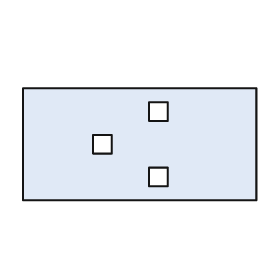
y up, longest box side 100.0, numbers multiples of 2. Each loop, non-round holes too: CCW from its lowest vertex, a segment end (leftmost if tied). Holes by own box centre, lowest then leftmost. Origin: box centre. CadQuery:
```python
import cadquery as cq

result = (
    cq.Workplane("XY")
    .moveTo(-50.0, -24.0)
    .lineTo(50.0, -24.0)
    .lineTo(50.0, 24.0)
    .lineTo(-50.0, 24.0)
    .close()
    .moveTo(4.0, -18.0)
    .lineTo(12.0, -18.0)
    .lineTo(12.0, -10.0)
    .lineTo(4.0, -10.0)
    .close()
    .moveTo(-20.0, -4.0)
    .lineTo(-12.0, -4.0)
    .lineTo(-12.0, 4.0)
    .lineTo(-20.0, 4.0)
    .close()
    .moveTo(4.0, 10.0)
    .lineTo(12.0, 10.0)
    .lineTo(12.0, 18.0)
    .lineTo(4.0, 18.0)
    .close()
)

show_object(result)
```